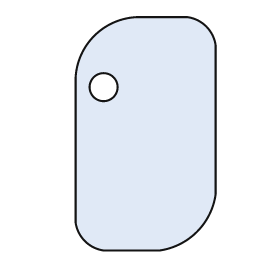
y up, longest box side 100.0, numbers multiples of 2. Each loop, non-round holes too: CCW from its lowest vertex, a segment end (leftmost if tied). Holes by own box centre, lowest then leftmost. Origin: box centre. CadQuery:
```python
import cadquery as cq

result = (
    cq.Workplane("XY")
    .moveTo(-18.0, -50.0)
    .lineTo(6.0, -50.0)
    .threePointArc((22.0, -42.0), (30.0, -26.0))
    .lineTo(30.0, 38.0)
    .threePointArc((26.0, 46.0), (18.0, 50.0))
    .lineTo(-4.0, 50.0)
    .threePointArc((-22.0, 42.0), (-30.0, 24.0))
    .lineTo(-30.0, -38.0)
    .threePointArc((-26.0, -46.0), (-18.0, -50.0))
    .close()
    .moveTo(-18.0, 20.0)
    .circle(6.0)
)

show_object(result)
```